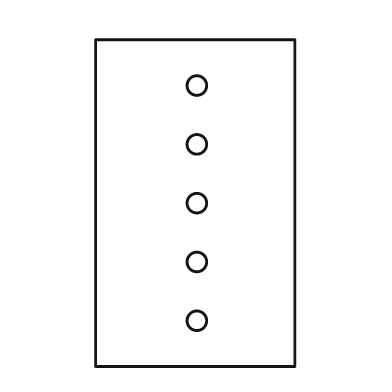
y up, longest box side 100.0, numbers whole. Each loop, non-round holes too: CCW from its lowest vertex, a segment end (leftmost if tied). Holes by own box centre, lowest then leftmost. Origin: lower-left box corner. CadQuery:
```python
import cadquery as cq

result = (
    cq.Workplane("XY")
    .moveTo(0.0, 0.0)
    .lineTo(61.0, 0.0)
    .lineTo(61.0, 100.0)
    .lineTo(0.0, 100.0)
    .close()
    .moveTo(31.0, 14.0)
    .circle(3.0)
    .moveTo(31.0, 32.0)
    .circle(3.0)
    .moveTo(31.0, 50.0)
    .circle(3.0)
    .moveTo(31.0, 68.0)
    .circle(3.0)
    .moveTo(31.0, 86.0)
    .circle(3.0)
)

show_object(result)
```